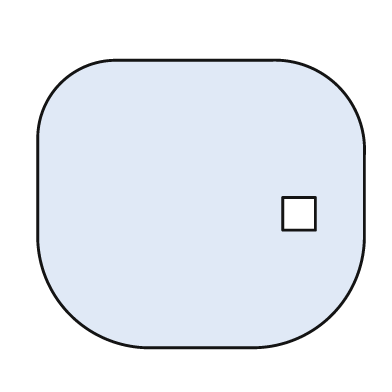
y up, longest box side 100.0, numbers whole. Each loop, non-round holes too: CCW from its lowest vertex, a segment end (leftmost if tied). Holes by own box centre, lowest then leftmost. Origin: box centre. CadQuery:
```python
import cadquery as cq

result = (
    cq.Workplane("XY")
    .moveTo(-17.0, -44.0)
    .lineTo(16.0, -44.0)
    .threePointArc((40.0, -34.0), (50.0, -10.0))
    .lineTo(50.0, 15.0)
    .threePointArc((42.0, 36.0), (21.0, 44.0))
    .lineTo(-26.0, 44.0)
    .threePointArc((-43.0, 37.0), (-50.0, 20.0))
    .lineTo(-50.0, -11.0)
    .threePointArc((-40.0, -34.0), (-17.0, -44.0))
    .close()
    .moveTo(25.0, -8.0)
    .lineTo(35.0, -8.0)
    .lineTo(35.0, 2.0)
    .lineTo(25.0, 2.0)
    .close()
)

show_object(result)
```